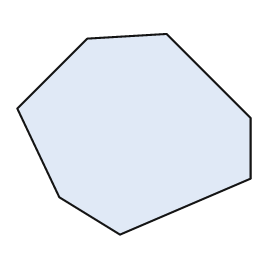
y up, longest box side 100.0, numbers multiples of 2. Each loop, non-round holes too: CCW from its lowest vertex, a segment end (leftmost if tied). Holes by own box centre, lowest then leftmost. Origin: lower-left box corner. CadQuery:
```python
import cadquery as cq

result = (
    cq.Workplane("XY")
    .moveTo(44.0, 0.0)
    .lineTo(100.0, 24.0)
    .lineTo(100.0, 50.0)
    .lineTo(64.0, 86.0)
    .lineTo(30.0, 84.0)
    .lineTo(0.0, 54.0)
    .lineTo(18.0, 16.0)
    .close()
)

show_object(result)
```